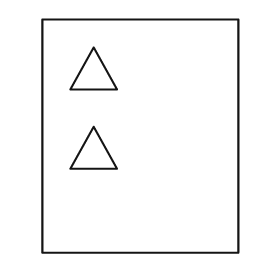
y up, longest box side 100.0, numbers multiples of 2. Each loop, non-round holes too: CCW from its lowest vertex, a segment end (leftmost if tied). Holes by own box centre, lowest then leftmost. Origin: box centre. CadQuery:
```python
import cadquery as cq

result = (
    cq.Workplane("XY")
    .moveTo(-42.0, -50.0)
    .lineTo(42.0, -50.0)
    .lineTo(42.0, 50.0)
    .lineTo(-42.0, 50.0)
    .close()
    .moveTo(-30.0, -14.0)
    .lineTo(-10.0, -14.0)
    .lineTo(-20.0, 4.0)
    .close()
    .moveTo(-30.0, 20.0)
    .lineTo(-10.0, 20.0)
    .lineTo(-20.0, 38.0)
    .close()
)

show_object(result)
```